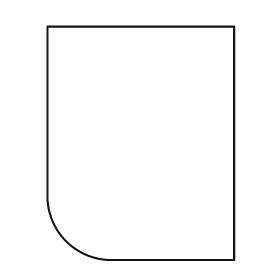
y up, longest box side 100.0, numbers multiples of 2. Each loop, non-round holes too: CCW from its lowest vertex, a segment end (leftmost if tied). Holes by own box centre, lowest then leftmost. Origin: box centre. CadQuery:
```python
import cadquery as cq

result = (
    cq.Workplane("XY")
    .moveTo(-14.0, -50.0)
    .lineTo(40.0, -50.0)
    .lineTo(40.0, 50.0)
    .lineTo(-40.0, 50.0)
    .lineTo(-40.0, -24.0)
    .threePointArc((-32.0, -42.0), (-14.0, -50.0))
    .close()
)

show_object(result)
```